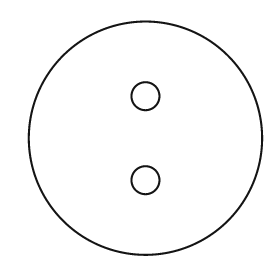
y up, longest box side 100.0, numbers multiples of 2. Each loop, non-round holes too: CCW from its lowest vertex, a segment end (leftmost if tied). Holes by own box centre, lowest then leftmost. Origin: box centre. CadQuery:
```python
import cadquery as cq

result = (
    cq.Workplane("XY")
    .moveTo(0.0, 0.0)
    .circle(50.0)
    .moveTo(0.0, -18.0)
    .circle(6.0)
    .moveTo(0.0, 18.0)
    .circle(6.0)
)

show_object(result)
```